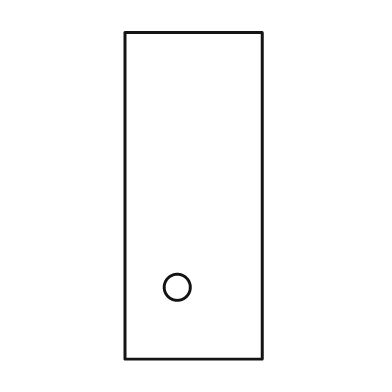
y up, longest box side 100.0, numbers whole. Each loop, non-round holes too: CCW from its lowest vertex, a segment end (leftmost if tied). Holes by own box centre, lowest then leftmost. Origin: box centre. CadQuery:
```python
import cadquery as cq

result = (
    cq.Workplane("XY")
    .moveTo(-21.0, -50.0)
    .lineTo(21.0, -50.0)
    .lineTo(21.0, 50.0)
    .lineTo(-21.0, 50.0)
    .close()
    .moveTo(-5.0, -28.0)
    .circle(4.0)
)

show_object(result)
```